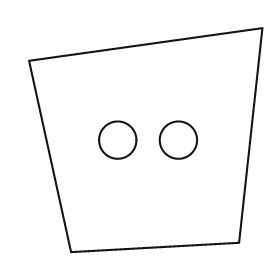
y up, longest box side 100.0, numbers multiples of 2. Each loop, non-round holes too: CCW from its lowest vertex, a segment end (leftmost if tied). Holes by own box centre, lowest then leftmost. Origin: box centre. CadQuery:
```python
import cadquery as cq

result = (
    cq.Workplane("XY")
    .moveTo(-32.0, -48.0)
    .lineTo(40.0, -44.0)
    .lineTo(50.0, 48.0)
    .lineTo(-50.0, 34.0)
    .close()
    .moveTo(-12.0, 0.0)
    .circle(8.0)
    .moveTo(14.0, 0.0)
    .circle(8.0)
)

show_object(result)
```